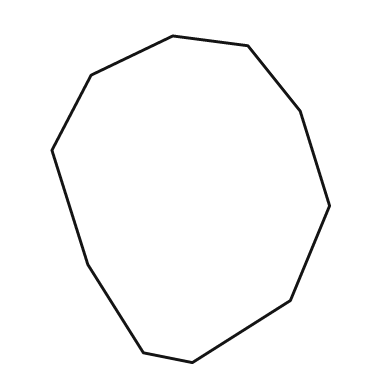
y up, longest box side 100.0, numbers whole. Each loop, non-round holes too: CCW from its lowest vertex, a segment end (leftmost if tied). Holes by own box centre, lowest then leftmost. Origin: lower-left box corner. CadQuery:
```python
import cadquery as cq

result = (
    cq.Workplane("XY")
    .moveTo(43.0, 0.0)
    .lineTo(73.0, 19.0)
    .lineTo(85.0, 48.0)
    .lineTo(76.0, 77.0)
    .lineTo(60.0, 97.0)
    .lineTo(37.0, 100.0)
    .lineTo(12.0, 88.0)
    .lineTo(0.0, 65.0)
    .lineTo(11.0, 30.0)
    .lineTo(28.0, 3.0)
    .close()
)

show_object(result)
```